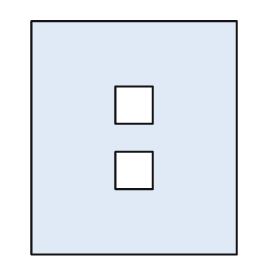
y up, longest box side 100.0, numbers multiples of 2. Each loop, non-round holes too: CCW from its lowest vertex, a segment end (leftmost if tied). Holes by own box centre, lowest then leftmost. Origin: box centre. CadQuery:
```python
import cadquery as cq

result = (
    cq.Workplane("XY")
    .moveTo(-44.0, -50.0)
    .lineTo(44.0, -50.0)
    .lineTo(44.0, 50.0)
    .lineTo(-44.0, 50.0)
    .close()
    .moveTo(-8.0, -22.0)
    .lineTo(8.0, -22.0)
    .lineTo(8.0, -6.0)
    .lineTo(-8.0, -6.0)
    .close()
    .moveTo(-8.0, 6.0)
    .lineTo(8.0, 6.0)
    .lineTo(8.0, 22.0)
    .lineTo(-8.0, 22.0)
    .close()
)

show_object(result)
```